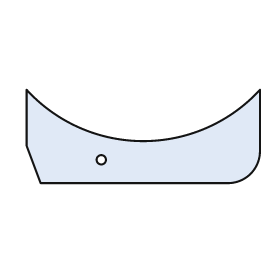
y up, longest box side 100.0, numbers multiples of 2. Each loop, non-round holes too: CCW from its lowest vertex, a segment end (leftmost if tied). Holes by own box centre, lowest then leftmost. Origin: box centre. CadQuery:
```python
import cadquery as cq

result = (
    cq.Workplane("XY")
    .moveTo(-44.0, -20.0)
    .lineTo(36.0, -20.0)
    .threePointArc((46.0, -16.0), (50.0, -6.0))
    .lineTo(50.0, 20.0)
    .threePointArc((0.0, -2.0), (-50.0, 20.0))
    .lineTo(-50.0, -4.0)
    .close()
    .moveTo(-18.0, -10.0)
    .circle(2.0)
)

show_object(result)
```